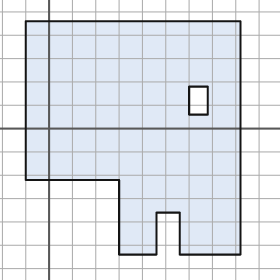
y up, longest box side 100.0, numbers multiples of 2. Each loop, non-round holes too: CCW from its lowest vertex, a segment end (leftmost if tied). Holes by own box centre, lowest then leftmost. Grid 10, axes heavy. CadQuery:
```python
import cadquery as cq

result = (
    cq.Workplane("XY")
    .moveTo(30.0, -54.0)
    .lineTo(46.0, -54.0)
    .lineTo(46.0, -36.0)
    .lineTo(56.0, -36.0)
    .lineTo(56.0, -54.0)
    .lineTo(82.0, -54.0)
    .lineTo(82.0, 46.0)
    .lineTo(-10.0, 46.0)
    .lineTo(-10.0, -22.0)
    .lineTo(30.0, -22.0)
    .close()
    .moveTo(60.0, 6.0)
    .lineTo(68.0, 6.0)
    .lineTo(68.0, 18.0)
    .lineTo(60.0, 18.0)
    .close()
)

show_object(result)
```